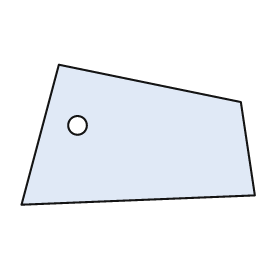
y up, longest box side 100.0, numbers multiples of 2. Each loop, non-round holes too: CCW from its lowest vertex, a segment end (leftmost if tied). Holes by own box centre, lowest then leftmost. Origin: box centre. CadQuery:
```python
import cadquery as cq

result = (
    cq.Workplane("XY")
    .moveTo(-50.0, -30.0)
    .lineTo(50.0, -26.0)
    .lineTo(44.0, 14.0)
    .lineTo(-34.0, 30.0)
    .close()
    .moveTo(-26.0, 4.0)
    .circle(4.0)
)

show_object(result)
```